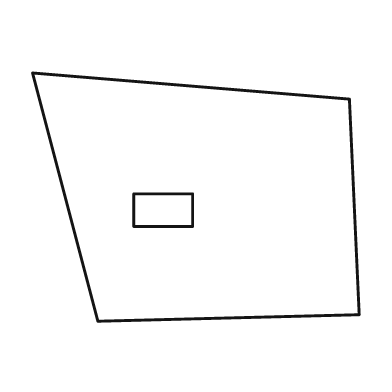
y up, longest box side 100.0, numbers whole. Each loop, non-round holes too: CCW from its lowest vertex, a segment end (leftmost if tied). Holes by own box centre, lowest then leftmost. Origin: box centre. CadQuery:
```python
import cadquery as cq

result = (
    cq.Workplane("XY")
    .moveTo(-30.0, -38.0)
    .lineTo(50.0, -36.0)
    .lineTo(47.0, 30.0)
    .lineTo(-50.0, 38.0)
    .close()
    .moveTo(-19.0, -9.0)
    .lineTo(-1.0, -9.0)
    .lineTo(-1.0, 1.0)
    .lineTo(-19.0, 1.0)
    .close()
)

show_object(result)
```